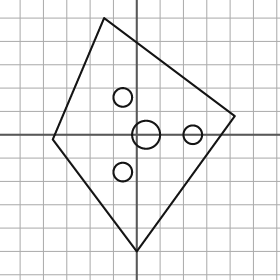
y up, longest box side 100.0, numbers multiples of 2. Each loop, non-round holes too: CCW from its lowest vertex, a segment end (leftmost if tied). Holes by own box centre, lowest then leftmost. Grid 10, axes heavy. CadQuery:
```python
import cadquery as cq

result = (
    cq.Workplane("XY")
    .moveTo(0.0, -50.0)
    .lineTo(42.0, 8.0)
    .lineTo(-14.0, 50.0)
    .lineTo(-36.0, -2.0)
    .close()
    .moveTo(-6.0, -16.0)
    .circle(4.0)
    .moveTo(4.0, 0.0)
    .circle(6.0)
    .moveTo(24.0, 0.0)
    .circle(4.0)
    .moveTo(-6.0, 16.0)
    .circle(4.0)
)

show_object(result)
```